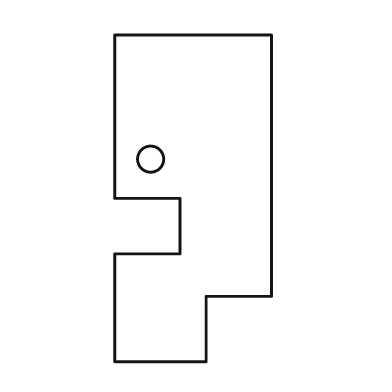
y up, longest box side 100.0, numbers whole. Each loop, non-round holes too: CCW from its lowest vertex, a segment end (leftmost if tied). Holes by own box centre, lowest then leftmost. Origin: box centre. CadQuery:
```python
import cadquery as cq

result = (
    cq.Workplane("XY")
    .moveTo(-24.0, -50.0)
    .lineTo(4.0, -50.0)
    .lineTo(4.0, -30.0)
    .lineTo(24.0, -30.0)
    .lineTo(24.0, 50.0)
    .lineTo(-24.0, 50.0)
    .lineTo(-24.0, 0.0)
    .lineTo(-4.0, 0.0)
    .lineTo(-4.0, -17.0)
    .lineTo(-24.0, -17.0)
    .close()
    .moveTo(-13.0, 12.0)
    .circle(4.0)
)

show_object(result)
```